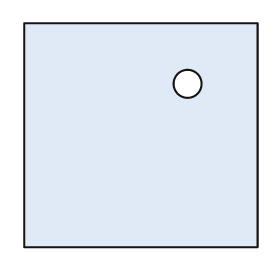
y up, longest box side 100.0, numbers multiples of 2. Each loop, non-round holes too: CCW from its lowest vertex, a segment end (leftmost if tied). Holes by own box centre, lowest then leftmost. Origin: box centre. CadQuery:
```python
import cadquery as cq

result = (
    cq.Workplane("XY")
    .moveTo(-50.0, -48.0)
    .lineTo(50.0, -48.0)
    .lineTo(50.0, 48.0)
    .lineTo(-50.0, 48.0)
    .close()
    .moveTo(20.0, 22.0)
    .circle(6.0)
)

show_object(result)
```